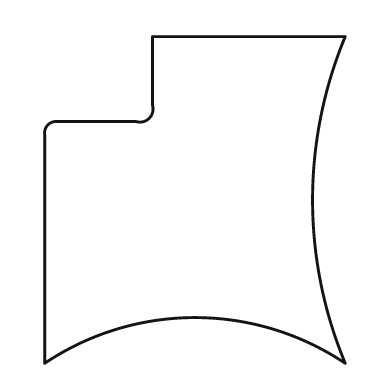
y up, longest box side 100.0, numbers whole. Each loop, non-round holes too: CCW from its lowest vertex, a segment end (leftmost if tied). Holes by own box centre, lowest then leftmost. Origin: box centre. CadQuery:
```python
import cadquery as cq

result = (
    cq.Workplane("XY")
    .moveTo(-46.0, -50.0)
    .threePointArc((0.0, -36.0), (46.0, -50.0))
    .threePointArc((36.0, 0.0), (46.0, 50.0))
    .lineTo(-13.0, 50.0)
    .lineTo(-13.0, 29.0)
    .threePointArc((-14.0, 25.0), (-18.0, 24.0))
    .lineTo(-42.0, 24.0)
    .threePointArc((-45.0, 23.0), (-46.0, 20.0))
    .close()
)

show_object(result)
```